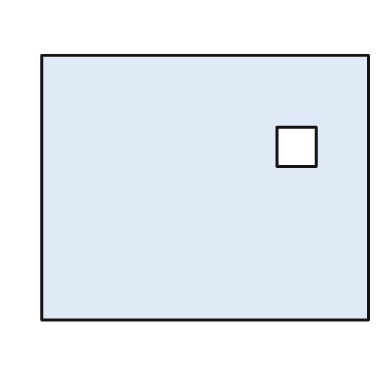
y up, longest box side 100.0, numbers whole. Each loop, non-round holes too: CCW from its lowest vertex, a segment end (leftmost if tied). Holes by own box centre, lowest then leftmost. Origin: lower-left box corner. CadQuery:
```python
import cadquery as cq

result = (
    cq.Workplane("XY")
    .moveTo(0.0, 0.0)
    .lineTo(100.0, 0.0)
    .lineTo(100.0, 81.0)
    .lineTo(0.0, 81.0)
    .close()
    .moveTo(72.0, 47.0)
    .lineTo(84.0, 47.0)
    .lineTo(84.0, 59.0)
    .lineTo(72.0, 59.0)
    .close()
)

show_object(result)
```